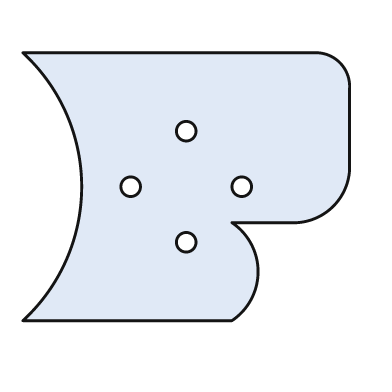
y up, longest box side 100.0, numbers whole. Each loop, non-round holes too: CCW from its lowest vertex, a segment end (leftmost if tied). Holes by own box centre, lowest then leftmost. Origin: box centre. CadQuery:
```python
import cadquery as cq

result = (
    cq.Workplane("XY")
    .moveTo(-50.0, -41.0)
    .lineTo(14.0, -41.0)
    .threePointArc((22.0, -26.0), (14.0, -11.0))
    .lineTo(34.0, -11.0)
    .threePointArc((45.0, -6.0), (50.0, 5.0))
    .lineTo(50.0, 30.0)
    .threePointArc((47.0, 38.0), (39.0, 41.0))
    .lineTo(-50.0, 41.0)
    .threePointArc((-32.0, 0.0), (-50.0, -41.0))
    .close()
    .moveTo(0.0, -17.0)
    .circle(3.0)
    .moveTo(-17.0, 0.0)
    .circle(3.0)
    .moveTo(17.0, 0.0)
    .circle(3.0)
    .moveTo(0.0, 17.0)
    .circle(3.0)
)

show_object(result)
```